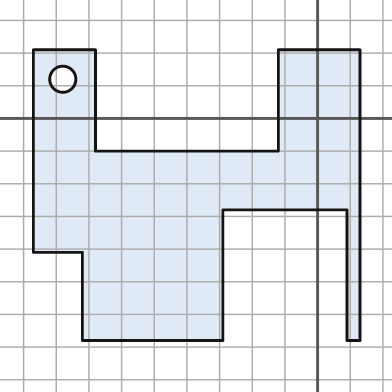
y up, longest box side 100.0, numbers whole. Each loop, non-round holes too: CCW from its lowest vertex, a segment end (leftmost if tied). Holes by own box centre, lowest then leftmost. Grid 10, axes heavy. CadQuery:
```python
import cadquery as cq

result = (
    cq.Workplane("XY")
    .moveTo(-72.0, -68.0)
    .lineTo(-29.0, -68.0)
    .lineTo(-29.0, -28.0)
    .lineTo(9.0, -28.0)
    .lineTo(9.0, -68.0)
    .lineTo(13.0, -68.0)
    .lineTo(13.0, 21.0)
    .lineTo(-12.0, 21.0)
    .lineTo(-12.0, -10.0)
    .lineTo(-68.0, -10.0)
    .lineTo(-68.0, 21.0)
    .lineTo(-87.0, 21.0)
    .lineTo(-87.0, -41.0)
    .lineTo(-72.0, -41.0)
    .close()
    .moveTo(-78.0, 12.0)
    .circle(4.0)
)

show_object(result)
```